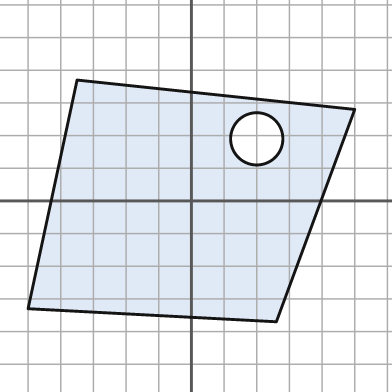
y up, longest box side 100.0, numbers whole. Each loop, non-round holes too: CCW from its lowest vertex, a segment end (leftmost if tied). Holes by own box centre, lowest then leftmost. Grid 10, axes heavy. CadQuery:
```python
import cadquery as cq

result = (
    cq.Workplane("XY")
    .moveTo(26.0, -37.0)
    .lineTo(50.0, 28.0)
    .lineTo(-35.0, 37.0)
    .lineTo(-50.0, -33.0)
    .close()
    .moveTo(20.0, 19.0)
    .circle(8.0)
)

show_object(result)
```